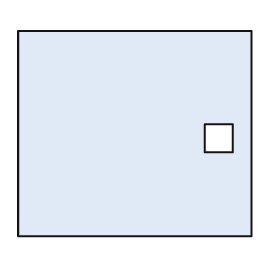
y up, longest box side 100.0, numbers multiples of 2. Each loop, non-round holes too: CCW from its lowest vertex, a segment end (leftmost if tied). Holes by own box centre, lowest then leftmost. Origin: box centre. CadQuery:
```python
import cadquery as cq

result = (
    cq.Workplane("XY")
    .moveTo(-50.0, -44.0)
    .lineTo(50.0, -44.0)
    .lineTo(50.0, 44.0)
    .lineTo(-50.0, 44.0)
    .close()
    .moveTo(30.0, -8.0)
    .lineTo(42.0, -8.0)
    .lineTo(42.0, 4.0)
    .lineTo(30.0, 4.0)
    .close()
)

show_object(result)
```